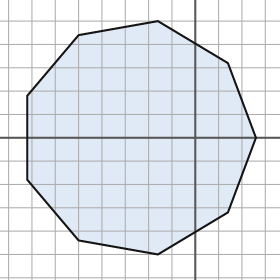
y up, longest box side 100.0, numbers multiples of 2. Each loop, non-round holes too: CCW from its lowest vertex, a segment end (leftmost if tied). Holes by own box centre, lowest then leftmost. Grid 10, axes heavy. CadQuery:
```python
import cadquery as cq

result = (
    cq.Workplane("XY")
    .moveTo(-16.0, -50.0)
    .lineTo(14.0, -32.0)
    .lineTo(26.0, 0.0)
    .lineTo(14.0, 32.0)
    .lineTo(-16.0, 50.0)
    .lineTo(-50.0, 44.0)
    .lineTo(-72.0, 18.0)
    .lineTo(-72.0, -18.0)
    .lineTo(-50.0, -44.0)
    .close()
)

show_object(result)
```